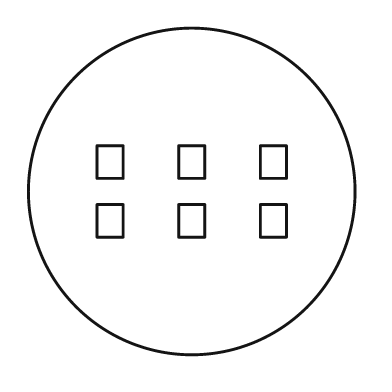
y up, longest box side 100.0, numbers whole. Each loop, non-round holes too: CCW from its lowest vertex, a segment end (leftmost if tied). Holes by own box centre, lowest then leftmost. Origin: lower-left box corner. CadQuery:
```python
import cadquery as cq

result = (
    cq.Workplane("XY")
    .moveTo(50.0, 50.0)
    .circle(50.0)
    .moveTo(21.0, 36.0)
    .lineTo(29.0, 36.0)
    .lineTo(29.0, 46.0)
    .lineTo(21.0, 46.0)
    .close()
    .moveTo(46.0, 36.0)
    .lineTo(54.0, 36.0)
    .lineTo(54.0, 46.0)
    .lineTo(46.0, 46.0)
    .close()
    .moveTo(71.0, 36.0)
    .lineTo(79.0, 36.0)
    .lineTo(79.0, 46.0)
    .lineTo(71.0, 46.0)
    .close()
    .moveTo(21.0, 54.0)
    .lineTo(29.0, 54.0)
    .lineTo(29.0, 64.0)
    .lineTo(21.0, 64.0)
    .close()
    .moveTo(46.0, 54.0)
    .lineTo(54.0, 54.0)
    .lineTo(54.0, 64.0)
    .lineTo(46.0, 64.0)
    .close()
    .moveTo(71.0, 54.0)
    .lineTo(79.0, 54.0)
    .lineTo(79.0, 64.0)
    .lineTo(71.0, 64.0)
    .close()
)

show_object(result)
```